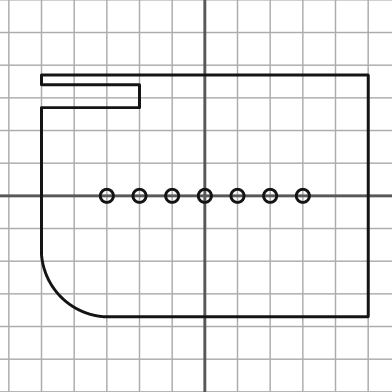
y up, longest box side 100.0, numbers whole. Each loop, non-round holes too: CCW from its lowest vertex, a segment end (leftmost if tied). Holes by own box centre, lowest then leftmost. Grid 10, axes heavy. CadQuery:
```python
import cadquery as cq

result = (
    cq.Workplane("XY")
    .moveTo(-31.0, -37.0)
    .lineTo(50.0, -37.0)
    .lineTo(50.0, 37.0)
    .lineTo(-50.0, 37.0)
    .lineTo(-50.0, 34.0)
    .lineTo(-20.0, 34.0)
    .lineTo(-20.0, 27.0)
    .lineTo(-50.0, 27.0)
    .lineTo(-50.0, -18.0)
    .threePointArc((-44.0, -31.0), (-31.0, -37.0))
    .close()
    .moveTo(-30.0, 0.0)
    .circle(2.0)
    .moveTo(-20.0, 0.0)
    .circle(2.0)
    .moveTo(-10.0, 0.0)
    .circle(2.0)
    .moveTo(0.0, 0.0)
    .circle(2.0)
    .moveTo(10.0, 0.0)
    .circle(2.0)
    .moveTo(20.0, 0.0)
    .circle(2.0)
    .moveTo(30.0, 0.0)
    .circle(2.0)
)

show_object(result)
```